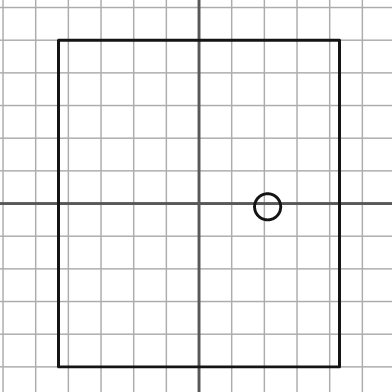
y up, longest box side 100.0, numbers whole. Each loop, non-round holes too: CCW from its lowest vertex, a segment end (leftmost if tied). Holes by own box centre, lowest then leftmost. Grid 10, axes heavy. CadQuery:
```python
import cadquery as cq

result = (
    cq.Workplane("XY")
    .moveTo(-43.0, -50.0)
    .lineTo(43.0, -50.0)
    .lineTo(43.0, 50.0)
    .lineTo(-43.0, 50.0)
    .close()
    .moveTo(21.0, -1.0)
    .circle(4.0)
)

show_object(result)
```